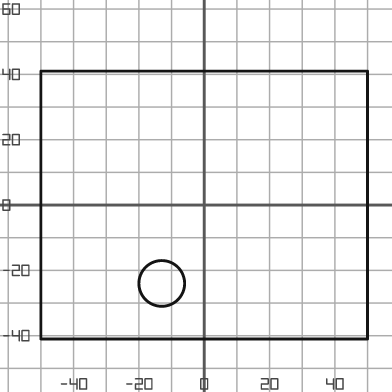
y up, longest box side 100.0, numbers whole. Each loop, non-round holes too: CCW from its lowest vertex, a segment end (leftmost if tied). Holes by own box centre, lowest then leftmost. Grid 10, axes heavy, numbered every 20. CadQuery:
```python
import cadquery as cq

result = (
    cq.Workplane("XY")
    .moveTo(-50.0, -41.0)
    .lineTo(50.0, -41.0)
    .lineTo(50.0, 41.0)
    .lineTo(-50.0, 41.0)
    .close()
    .moveTo(-13.0, -24.0)
    .circle(7.0)
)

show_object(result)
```